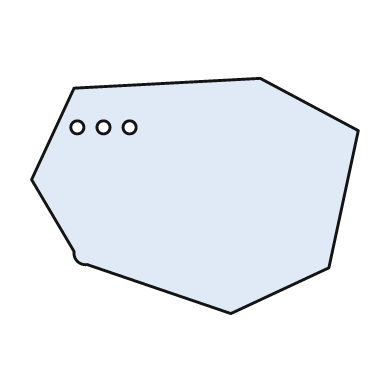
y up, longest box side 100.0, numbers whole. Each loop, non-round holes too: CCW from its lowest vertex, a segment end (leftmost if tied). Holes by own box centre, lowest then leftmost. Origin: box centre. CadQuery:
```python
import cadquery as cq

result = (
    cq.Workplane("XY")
    .moveTo(11.0, -36.0)
    .lineTo(41.0, -22.0)
    .lineTo(50.0, 20.0)
    .lineTo(20.0, 36.0)
    .lineTo(-37.0, 33.0)
    .lineTo(-50.0, 5.0)
    .lineTo(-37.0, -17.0)
    .threePointArc((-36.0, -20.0), (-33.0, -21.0))
    .close()
    .moveTo(-36.0, 21.0)
    .circle(2.0)
    .moveTo(-28.0, 21.0)
    .circle(2.0)
    .moveTo(-20.0, 21.0)
    .circle(2.0)
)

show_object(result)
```